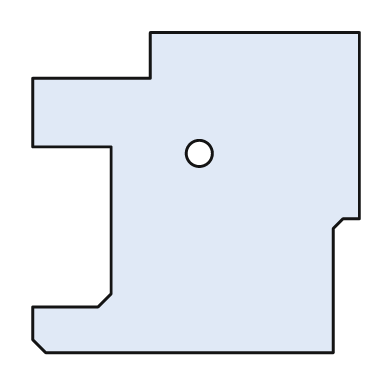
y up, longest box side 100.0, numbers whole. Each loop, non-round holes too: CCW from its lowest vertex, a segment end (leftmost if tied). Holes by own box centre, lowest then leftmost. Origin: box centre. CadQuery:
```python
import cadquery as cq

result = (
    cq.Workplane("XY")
    .moveTo(-46.0, -49.0)
    .lineTo(42.0, -49.0)
    .lineTo(42.0, -11.0)
    .lineTo(45.0, -8.0)
    .lineTo(50.0, -8.0)
    .lineTo(50.0, 49.0)
    .lineTo(-14.0, 49.0)
    .lineTo(-14.0, 35.0)
    .lineTo(-50.0, 35.0)
    .lineTo(-50.0, 14.0)
    .lineTo(-26.0, 14.0)
    .lineTo(-26.0, -31.0)
    .lineTo(-30.0, -35.0)
    .lineTo(-50.0, -35.0)
    .lineTo(-50.0, -45.0)
    .close()
    .moveTo(1.0, 12.0)
    .circle(4.0)
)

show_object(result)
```